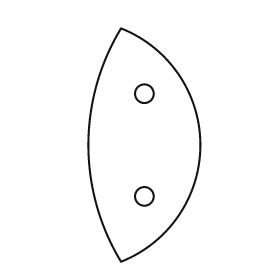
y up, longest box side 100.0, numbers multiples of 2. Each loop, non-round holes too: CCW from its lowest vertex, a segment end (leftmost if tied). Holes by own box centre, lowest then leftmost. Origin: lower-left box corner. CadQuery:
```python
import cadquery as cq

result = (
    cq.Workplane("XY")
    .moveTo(14.0, 0.0)
    .threePointArc((48.0, 50.0), (14.0, 100.0))
    .threePointArc((0.0, 50.0), (14.0, 0.0))
    .close()
    .moveTo(24.0, 28.0)
    .circle(4.0)
    .moveTo(24.0, 72.0)
    .circle(4.0)
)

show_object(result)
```